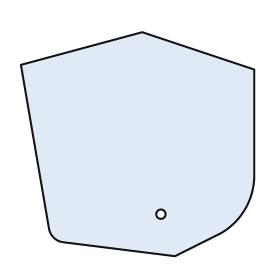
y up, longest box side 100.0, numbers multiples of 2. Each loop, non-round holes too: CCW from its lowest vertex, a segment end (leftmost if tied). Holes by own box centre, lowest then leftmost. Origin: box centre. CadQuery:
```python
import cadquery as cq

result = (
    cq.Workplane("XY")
    .moveTo(16.0, -48.0)
    .lineTo(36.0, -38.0)
    .threePointArc((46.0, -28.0), (50.0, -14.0))
    .lineTo(50.0, 32.0)
    .lineTo(2.0, 48.0)
    .lineTo(-50.0, 34.0)
    .lineTo(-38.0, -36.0)
    .threePointArc((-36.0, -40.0), (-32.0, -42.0))
    .close()
    .moveTo(10.0, -30.0)
    .circle(2.0)
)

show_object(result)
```